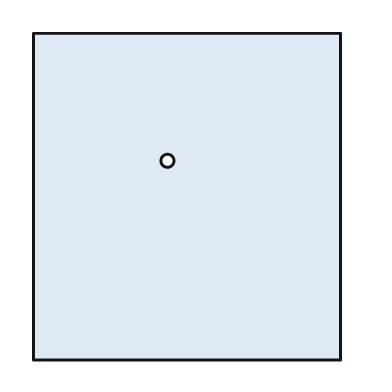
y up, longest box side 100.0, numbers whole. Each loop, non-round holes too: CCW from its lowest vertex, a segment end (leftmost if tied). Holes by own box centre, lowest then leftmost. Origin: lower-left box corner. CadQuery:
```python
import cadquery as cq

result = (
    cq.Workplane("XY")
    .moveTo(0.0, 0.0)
    .lineTo(94.0, 0.0)
    .lineTo(94.0, 100.0)
    .lineTo(0.0, 100.0)
    .close()
    .moveTo(41.0, 61.0)
    .circle(2.0)
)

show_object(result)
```